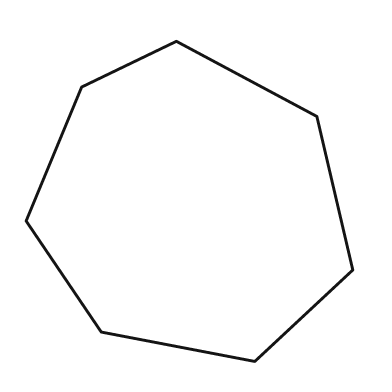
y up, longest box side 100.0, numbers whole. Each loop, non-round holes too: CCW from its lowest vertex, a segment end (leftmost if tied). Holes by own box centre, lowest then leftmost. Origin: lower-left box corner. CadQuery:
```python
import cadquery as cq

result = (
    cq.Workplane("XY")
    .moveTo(70.0, 0.0)
    .lineTo(100.0, 28.0)
    .lineTo(89.0, 75.0)
    .lineTo(46.0, 98.0)
    .lineTo(17.0, 84.0)
    .lineTo(0.0, 43.0)
    .lineTo(23.0, 9.0)
    .close()
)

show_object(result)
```